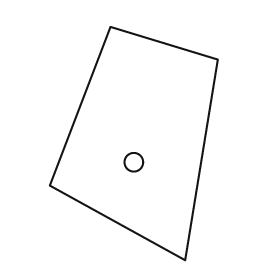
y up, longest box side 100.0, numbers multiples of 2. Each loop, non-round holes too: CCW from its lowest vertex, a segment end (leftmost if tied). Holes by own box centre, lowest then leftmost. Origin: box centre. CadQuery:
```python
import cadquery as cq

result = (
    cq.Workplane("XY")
    .moveTo(22.0, -50.0)
    .lineTo(36.0, 36.0)
    .lineTo(-10.0, 50.0)
    .lineTo(-36.0, -18.0)
    .close()
    .moveTo(0.0, -8.0)
    .circle(4.0)
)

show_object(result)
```